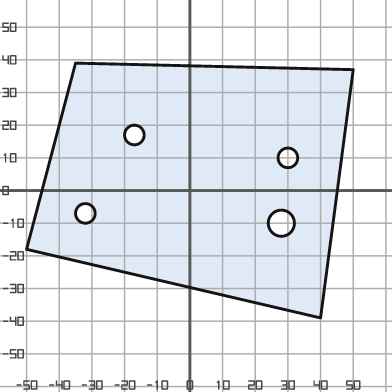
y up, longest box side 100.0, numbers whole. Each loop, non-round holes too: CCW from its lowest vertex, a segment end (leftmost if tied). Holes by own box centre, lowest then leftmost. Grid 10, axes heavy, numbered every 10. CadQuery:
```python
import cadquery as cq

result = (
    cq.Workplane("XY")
    .moveTo(40.0, -39.0)
    .lineTo(50.0, 37.0)
    .lineTo(-35.0, 39.0)
    .lineTo(-50.0, -18.0)
    .close()
    .moveTo(28.0, -10.0)
    .circle(4.0)
    .moveTo(-32.0, -7.0)
    .circle(3.0)
    .moveTo(30.0, 10.0)
    .circle(3.0)
    .moveTo(-17.0, 17.0)
    .circle(3.0)
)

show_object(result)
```